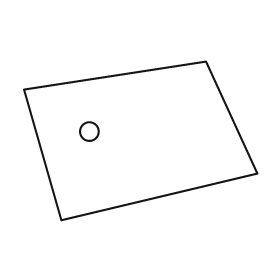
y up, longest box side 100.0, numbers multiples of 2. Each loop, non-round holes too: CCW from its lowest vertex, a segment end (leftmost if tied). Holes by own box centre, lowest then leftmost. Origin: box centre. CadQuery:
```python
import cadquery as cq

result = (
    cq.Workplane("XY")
    .moveTo(-34.0, -34.0)
    .lineTo(50.0, -14.0)
    .lineTo(28.0, 34.0)
    .lineTo(-50.0, 22.0)
    .close()
    .moveTo(-22.0, 4.0)
    .circle(4.0)
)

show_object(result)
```